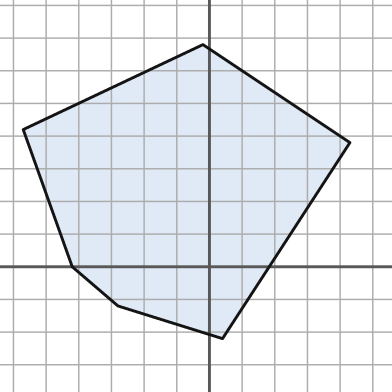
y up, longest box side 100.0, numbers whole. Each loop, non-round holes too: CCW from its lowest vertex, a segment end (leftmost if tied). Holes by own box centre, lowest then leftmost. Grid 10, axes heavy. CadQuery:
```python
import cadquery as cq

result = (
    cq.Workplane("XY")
    .moveTo(4.0, -22.0)
    .lineTo(43.0, 38.0)
    .lineTo(-2.0, 68.0)
    .lineTo(-57.0, 42.0)
    .lineTo(-42.0, 0.0)
    .lineTo(-28.0, -12.0)
    .close()
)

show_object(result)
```